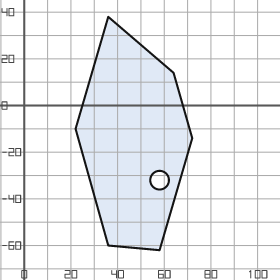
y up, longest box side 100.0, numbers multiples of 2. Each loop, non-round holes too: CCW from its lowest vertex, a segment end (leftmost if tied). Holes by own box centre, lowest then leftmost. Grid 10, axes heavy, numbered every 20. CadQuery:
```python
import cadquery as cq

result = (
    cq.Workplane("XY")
    .moveTo(58.0, -62.0)
    .lineTo(72.0, -14.0)
    .lineTo(64.0, 14.0)
    .lineTo(36.0, 38.0)
    .lineTo(22.0, -10.0)
    .lineTo(36.0, -60.0)
    .close()
    .moveTo(58.0, -32.0)
    .circle(4.0)
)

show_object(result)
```